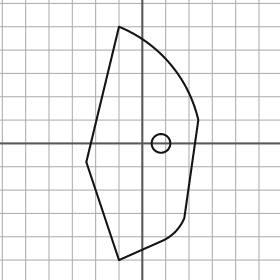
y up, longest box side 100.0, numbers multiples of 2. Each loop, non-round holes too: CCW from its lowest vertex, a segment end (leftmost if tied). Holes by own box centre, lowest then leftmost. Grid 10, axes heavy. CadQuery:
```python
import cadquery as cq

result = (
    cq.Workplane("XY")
    .moveTo(-10.0, -50.0)
    .lineTo(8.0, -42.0)
    .threePointArc((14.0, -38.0), (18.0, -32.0))
    .lineTo(24.0, 10.0)
    .threePointArc((12.0, 34.0), (-10.0, 50.0))
    .lineTo(-24.0, -8.0)
    .close()
    .moveTo(8.0, 0.0)
    .circle(4.0)
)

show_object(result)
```